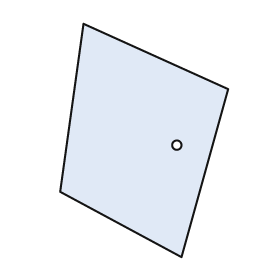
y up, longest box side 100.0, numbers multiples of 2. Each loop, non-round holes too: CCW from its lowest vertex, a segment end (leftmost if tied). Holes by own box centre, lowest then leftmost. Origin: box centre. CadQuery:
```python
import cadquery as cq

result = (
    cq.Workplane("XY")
    .moveTo(16.0, -50.0)
    .lineTo(36.0, 22.0)
    .lineTo(-26.0, 50.0)
    .lineTo(-36.0, -22.0)
    .close()
    .moveTo(14.0, -2.0)
    .circle(2.0)
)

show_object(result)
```